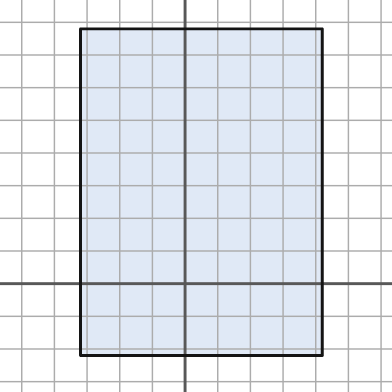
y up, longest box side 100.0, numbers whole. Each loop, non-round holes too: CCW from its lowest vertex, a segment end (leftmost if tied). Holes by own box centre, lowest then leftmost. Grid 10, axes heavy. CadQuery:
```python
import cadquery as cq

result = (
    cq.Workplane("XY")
    .moveTo(-32.0, -22.0)
    .lineTo(42.0, -22.0)
    .lineTo(42.0, 78.0)
    .lineTo(-32.0, 78.0)
    .close()
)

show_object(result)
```